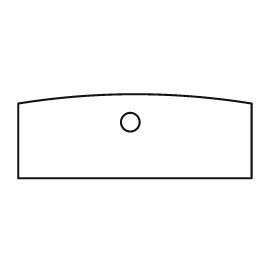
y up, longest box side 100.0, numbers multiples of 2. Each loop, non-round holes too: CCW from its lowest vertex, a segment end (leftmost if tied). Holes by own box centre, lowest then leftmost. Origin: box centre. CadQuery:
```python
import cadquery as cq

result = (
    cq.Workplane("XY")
    .moveTo(-50.0, -18.0)
    .lineTo(50.0, -18.0)
    .lineTo(50.0, 14.0)
    .threePointArc((0.0, 18.0), (-50.0, 14.0))
    .close()
    .moveTo(-2.0, 6.0)
    .circle(4.0)
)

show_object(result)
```